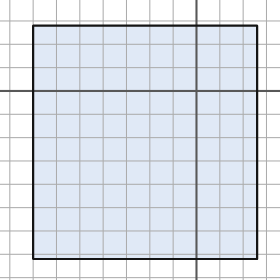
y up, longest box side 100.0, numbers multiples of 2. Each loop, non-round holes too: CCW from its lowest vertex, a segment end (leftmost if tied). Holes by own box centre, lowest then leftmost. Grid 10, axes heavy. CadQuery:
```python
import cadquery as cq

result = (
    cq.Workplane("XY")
    .moveTo(-70.0, -72.0)
    .lineTo(26.0, -72.0)
    .lineTo(26.0, 28.0)
    .lineTo(-70.0, 28.0)
    .close()
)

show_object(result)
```